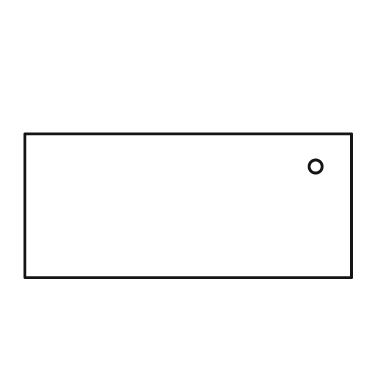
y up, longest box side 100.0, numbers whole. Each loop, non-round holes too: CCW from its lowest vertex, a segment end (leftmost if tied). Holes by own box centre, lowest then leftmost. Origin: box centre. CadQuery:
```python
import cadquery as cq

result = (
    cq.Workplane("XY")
    .moveTo(-50.0, -22.0)
    .lineTo(50.0, -22.0)
    .lineTo(50.0, 22.0)
    .lineTo(-50.0, 22.0)
    .close()
    .moveTo(39.0, 12.0)
    .circle(2.0)
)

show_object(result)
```